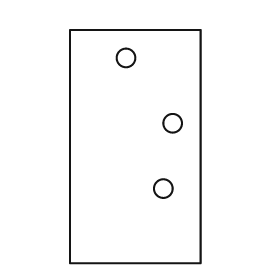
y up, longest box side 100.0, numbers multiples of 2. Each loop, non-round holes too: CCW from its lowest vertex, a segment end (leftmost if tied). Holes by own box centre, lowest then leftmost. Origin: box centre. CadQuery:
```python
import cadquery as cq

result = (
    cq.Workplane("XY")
    .moveTo(-28.0, -50.0)
    .lineTo(28.0, -50.0)
    .lineTo(28.0, 50.0)
    .lineTo(-28.0, 50.0)
    .close()
    .moveTo(12.0, -18.0)
    .circle(4.0)
    .moveTo(16.0, 10.0)
    .circle(4.0)
    .moveTo(-4.0, 38.0)
    .circle(4.0)
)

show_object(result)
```